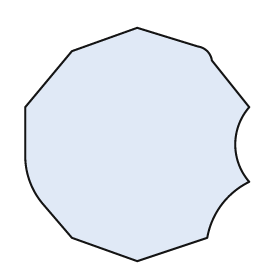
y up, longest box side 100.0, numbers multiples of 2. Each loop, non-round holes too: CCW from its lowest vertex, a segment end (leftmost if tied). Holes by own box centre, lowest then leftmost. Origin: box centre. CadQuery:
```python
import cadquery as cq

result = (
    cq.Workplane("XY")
    .moveTo(0.0, -50.0)
    .lineTo(30.0, -40.0)
    .threePointArc((36.0, -26.0), (48.0, -16.0))
    .threePointArc((42.0, 0.0), (48.0, 16.0))
    .lineTo(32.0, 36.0)
    .threePointArc((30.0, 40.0), (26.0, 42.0))
    .lineTo(0.0, 50.0)
    .lineTo(-28.0, 40.0)
    .lineTo(-48.0, 16.0)
    .lineTo(-48.0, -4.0)
    .threePointArc((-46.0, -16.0), (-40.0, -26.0))
    .lineTo(-28.0, -40.0)
    .close()
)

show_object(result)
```